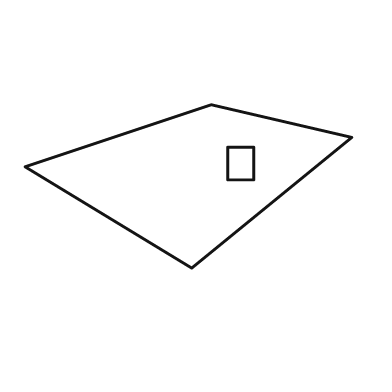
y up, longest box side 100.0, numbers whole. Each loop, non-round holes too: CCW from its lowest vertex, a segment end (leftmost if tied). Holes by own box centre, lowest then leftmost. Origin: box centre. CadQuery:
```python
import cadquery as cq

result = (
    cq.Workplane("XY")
    .moveTo(1.0, -25.0)
    .lineTo(50.0, 15.0)
    .lineTo(7.0, 25.0)
    .lineTo(-50.0, 6.0)
    .close()
    .moveTo(12.0, 2.0)
    .lineTo(20.0, 2.0)
    .lineTo(20.0, 12.0)
    .lineTo(12.0, 12.0)
    .close()
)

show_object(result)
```